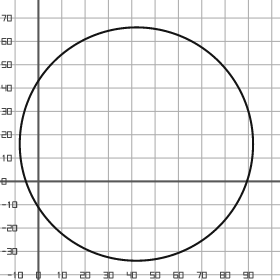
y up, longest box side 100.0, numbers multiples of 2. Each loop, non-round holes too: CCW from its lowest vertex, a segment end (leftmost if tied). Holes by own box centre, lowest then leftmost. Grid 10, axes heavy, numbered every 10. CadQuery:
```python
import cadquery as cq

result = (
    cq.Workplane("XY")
    .moveTo(42.0, 16.0)
    .circle(50.0)
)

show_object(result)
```